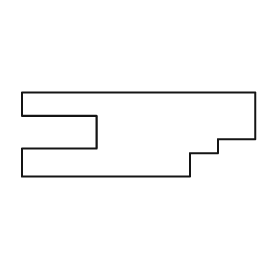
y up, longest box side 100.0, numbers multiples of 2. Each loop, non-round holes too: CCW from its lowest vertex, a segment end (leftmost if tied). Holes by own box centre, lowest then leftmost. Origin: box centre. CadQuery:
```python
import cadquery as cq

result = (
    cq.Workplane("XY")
    .moveTo(-50.0, -18.0)
    .lineTo(22.0, -18.0)
    .lineTo(22.0, -8.0)
    .lineTo(34.0, -8.0)
    .lineTo(34.0, -2.0)
    .lineTo(50.0, -2.0)
    .lineTo(50.0, 18.0)
    .lineTo(-50.0, 18.0)
    .lineTo(-50.0, 8.0)
    .lineTo(-18.0, 8.0)
    .lineTo(-18.0, -6.0)
    .lineTo(-50.0, -6.0)
    .close()
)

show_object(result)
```